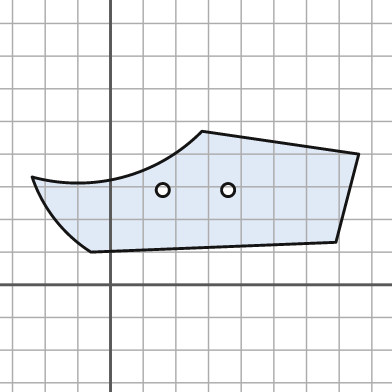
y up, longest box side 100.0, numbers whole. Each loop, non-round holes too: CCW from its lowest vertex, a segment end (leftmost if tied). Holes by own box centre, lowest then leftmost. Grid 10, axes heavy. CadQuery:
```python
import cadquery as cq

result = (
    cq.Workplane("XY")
    .moveTo(-6.0, 10.0)
    .lineTo(69.0, 13.0)
    .lineTo(76.0, 40.0)
    .lineTo(28.0, 47.0)
    .threePointArc((4.0, 33.0), (-24.0, 33.0))
    .threePointArc((-17.0, 20.0), (-6.0, 10.0))
    .close()
    .moveTo(16.0, 29.0)
    .circle(2.0)
    .moveTo(36.0, 29.0)
    .circle(2.0)
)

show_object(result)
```